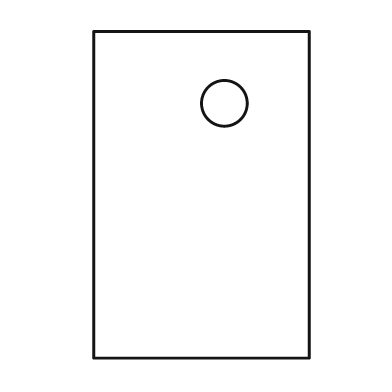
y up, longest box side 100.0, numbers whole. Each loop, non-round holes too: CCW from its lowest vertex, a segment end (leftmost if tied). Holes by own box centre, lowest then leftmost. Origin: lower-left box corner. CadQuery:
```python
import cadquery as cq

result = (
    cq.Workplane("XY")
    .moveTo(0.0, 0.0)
    .lineTo(66.0, 0.0)
    .lineTo(66.0, 100.0)
    .lineTo(0.0, 100.0)
    .close()
    .moveTo(40.0, 78.0)
    .circle(7.0)
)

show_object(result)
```